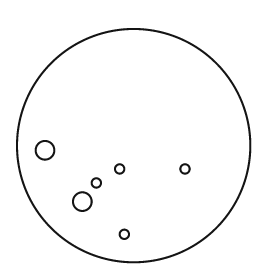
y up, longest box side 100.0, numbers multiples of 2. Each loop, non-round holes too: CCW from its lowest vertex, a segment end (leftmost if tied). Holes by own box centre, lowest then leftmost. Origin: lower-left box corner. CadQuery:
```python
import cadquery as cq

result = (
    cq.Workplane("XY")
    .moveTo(50.0, 50.0)
    .circle(50.0)
    .moveTo(46.0, 12.0)
    .circle(2.0)
    .moveTo(28.0, 26.0)
    .circle(4.0)
    .moveTo(34.0, 34.0)
    .circle(2.0)
    .moveTo(44.0, 40.0)
    .circle(2.0)
    .moveTo(72.0, 40.0)
    .circle(2.0)
    .moveTo(12.0, 48.0)
    .circle(4.0)
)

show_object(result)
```